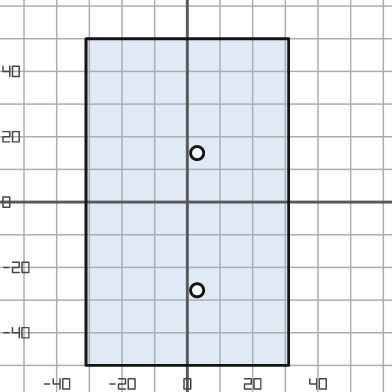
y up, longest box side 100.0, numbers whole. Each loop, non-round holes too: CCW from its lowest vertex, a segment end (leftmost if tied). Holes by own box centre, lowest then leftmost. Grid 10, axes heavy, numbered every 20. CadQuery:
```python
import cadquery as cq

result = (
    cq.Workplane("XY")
    .moveTo(-31.0, -50.0)
    .lineTo(31.0, -50.0)
    .lineTo(31.0, 50.0)
    .lineTo(-31.0, 50.0)
    .close()
    .moveTo(3.0, -27.0)
    .circle(2.0)
    .moveTo(3.0, 15.0)
    .circle(2.0)
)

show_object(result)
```